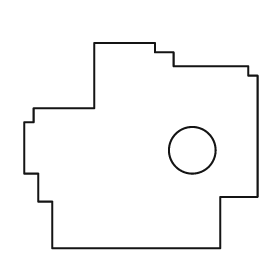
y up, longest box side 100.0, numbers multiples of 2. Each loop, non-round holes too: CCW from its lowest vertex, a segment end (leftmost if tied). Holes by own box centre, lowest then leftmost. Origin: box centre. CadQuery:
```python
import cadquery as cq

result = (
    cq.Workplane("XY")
    .moveTo(-38.0, -44.0)
    .lineTo(34.0, -44.0)
    .lineTo(34.0, -22.0)
    .lineTo(50.0, -22.0)
    .lineTo(50.0, 30.0)
    .lineTo(46.0, 30.0)
    .lineTo(46.0, 34.0)
    .lineTo(14.0, 34.0)
    .lineTo(14.0, 40.0)
    .lineTo(6.0, 40.0)
    .lineTo(6.0, 44.0)
    .lineTo(-20.0, 44.0)
    .lineTo(-20.0, 16.0)
    .lineTo(-46.0, 16.0)
    .lineTo(-46.0, 10.0)
    .lineTo(-50.0, 10.0)
    .lineTo(-50.0, -12.0)
    .lineTo(-44.0, -12.0)
    .lineTo(-44.0, -24.0)
    .lineTo(-38.0, -24.0)
    .close()
    .moveTo(22.0, -2.0)
    .circle(10.0)
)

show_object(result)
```